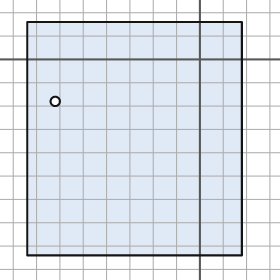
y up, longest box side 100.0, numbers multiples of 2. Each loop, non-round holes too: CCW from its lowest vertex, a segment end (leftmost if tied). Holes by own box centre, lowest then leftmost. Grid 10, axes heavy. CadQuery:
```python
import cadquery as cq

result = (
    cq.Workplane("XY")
    .moveTo(-74.0, -84.0)
    .lineTo(18.0, -84.0)
    .lineTo(18.0, 16.0)
    .lineTo(-74.0, 16.0)
    .close()
    .moveTo(-62.0, -18.0)
    .circle(2.0)
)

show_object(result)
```